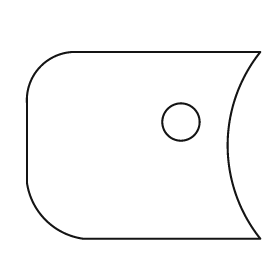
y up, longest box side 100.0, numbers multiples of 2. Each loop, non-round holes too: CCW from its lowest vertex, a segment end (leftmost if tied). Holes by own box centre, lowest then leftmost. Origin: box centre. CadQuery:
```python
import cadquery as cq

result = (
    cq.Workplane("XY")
    .moveTo(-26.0, -40.0)
    .lineTo(50.0, -40.0)
    .threePointArc((36.0, 0.0), (50.0, 40.0))
    .lineTo(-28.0, 40.0)
    .threePointArc((-44.0, 34.0), (-50.0, 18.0))
    .lineTo(-50.0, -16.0)
    .threePointArc((-42.0, -32.0), (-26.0, -40.0))
    .close()
    .moveTo(16.0, 10.0)
    .circle(8.0)
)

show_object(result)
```